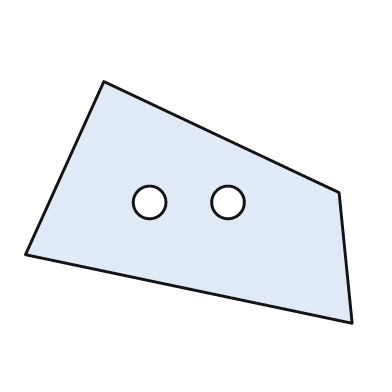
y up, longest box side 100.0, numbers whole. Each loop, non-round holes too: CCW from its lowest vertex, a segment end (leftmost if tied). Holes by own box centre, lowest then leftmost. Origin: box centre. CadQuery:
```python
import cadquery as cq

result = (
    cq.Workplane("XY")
    .moveTo(50.0, -37.0)
    .lineTo(46.0, 3.0)
    .lineTo(-26.0, 37.0)
    .lineTo(-50.0, -16.0)
    .close()
    .moveTo(-12.0, 0.0)
    .circle(5.0)
    .moveTo(12.0, 0.0)
    .circle(5.0)
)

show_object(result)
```